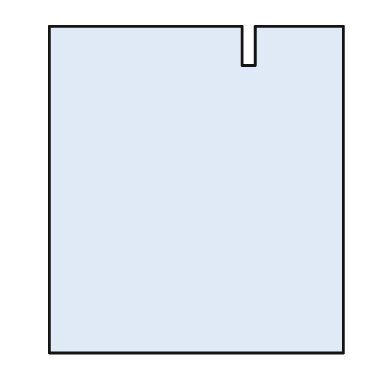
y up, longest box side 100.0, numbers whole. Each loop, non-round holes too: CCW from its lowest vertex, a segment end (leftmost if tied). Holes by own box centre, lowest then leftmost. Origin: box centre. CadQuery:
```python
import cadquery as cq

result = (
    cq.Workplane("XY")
    .moveTo(-45.0, -50.0)
    .lineTo(45.0, -50.0)
    .lineTo(45.0, 50.0)
    .lineTo(18.0, 50.0)
    .lineTo(18.0, 38.0)
    .lineTo(14.0, 38.0)
    .lineTo(14.0, 50.0)
    .lineTo(-45.0, 50.0)
    .close()
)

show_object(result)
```